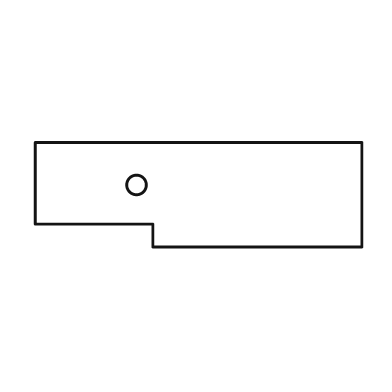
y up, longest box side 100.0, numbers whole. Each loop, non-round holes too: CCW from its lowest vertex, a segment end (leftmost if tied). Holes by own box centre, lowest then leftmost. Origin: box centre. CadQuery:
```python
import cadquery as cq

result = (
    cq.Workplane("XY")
    .moveTo(-14.0, -16.0)
    .lineTo(50.0, -16.0)
    .lineTo(50.0, 16.0)
    .lineTo(-50.0, 16.0)
    .lineTo(-50.0, -9.0)
    .lineTo(-14.0, -9.0)
    .close()
    .moveTo(-19.0, 3.0)
    .circle(3.0)
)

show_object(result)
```